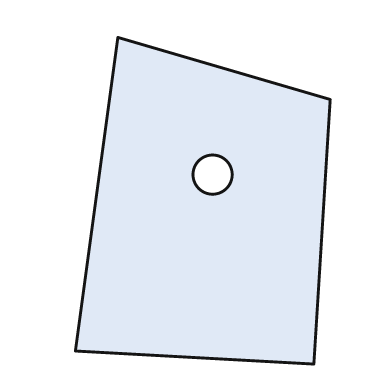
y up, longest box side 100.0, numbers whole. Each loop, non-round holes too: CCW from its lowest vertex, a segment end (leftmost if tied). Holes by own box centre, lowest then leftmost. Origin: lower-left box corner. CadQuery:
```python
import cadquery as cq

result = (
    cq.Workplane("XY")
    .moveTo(73.0, 0.0)
    .lineTo(78.0, 81.0)
    .lineTo(13.0, 100.0)
    .lineTo(0.0, 4.0)
    .close()
    .moveTo(42.0, 58.0)
    .circle(6.0)
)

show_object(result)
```